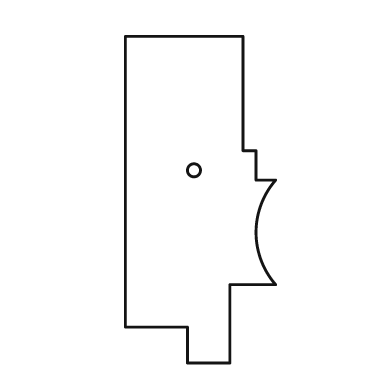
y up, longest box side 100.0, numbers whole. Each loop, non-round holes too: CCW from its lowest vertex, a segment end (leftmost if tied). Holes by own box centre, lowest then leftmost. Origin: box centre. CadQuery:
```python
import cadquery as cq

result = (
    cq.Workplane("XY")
    .moveTo(-4.0, -50.0)
    .lineTo(9.0, -50.0)
    .lineTo(9.0, -26.0)
    .lineTo(23.0, -26.0)
    .threePointArc((17.0, -10.0), (23.0, 6.0))
    .lineTo(17.0, 6.0)
    .lineTo(17.0, 15.0)
    .lineTo(13.0, 15.0)
    .lineTo(13.0, 50.0)
    .lineTo(-23.0, 50.0)
    .lineTo(-23.0, -39.0)
    .lineTo(-4.0, -39.0)
    .close()
    .moveTo(-2.0, 9.0)
    .circle(2.0)
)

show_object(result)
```